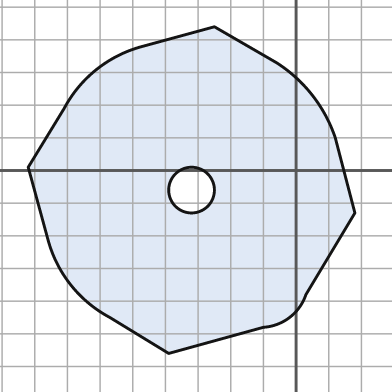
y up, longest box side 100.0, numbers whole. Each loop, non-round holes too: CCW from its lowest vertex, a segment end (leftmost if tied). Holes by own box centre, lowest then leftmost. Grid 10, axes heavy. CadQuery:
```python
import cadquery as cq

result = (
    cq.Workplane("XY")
    .moveTo(-39.0, -56.0)
    .lineTo(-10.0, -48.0)
    .threePointArc((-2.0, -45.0), (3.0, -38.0))
    .lineTo(18.0, -13.0)
    .lineTo(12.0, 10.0)
    .threePointArc((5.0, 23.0), (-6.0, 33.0))
    .lineTo(-25.0, 44.0)
    .lineTo(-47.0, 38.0)
    .threePointArc((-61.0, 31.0), (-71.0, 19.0))
    .lineTo(-82.0, 1.0)
    .lineTo(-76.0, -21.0)
    .threePointArc((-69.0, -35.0), (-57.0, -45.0))
    .close()
    .moveTo(-32.0, -6.0)
    .circle(7.0)
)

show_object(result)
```